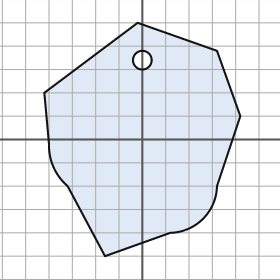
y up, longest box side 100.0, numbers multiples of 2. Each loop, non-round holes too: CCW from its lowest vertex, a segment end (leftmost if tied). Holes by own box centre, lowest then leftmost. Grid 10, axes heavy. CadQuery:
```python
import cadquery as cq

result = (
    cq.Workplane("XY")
    .moveTo(-16.0, -50.0)
    .lineTo(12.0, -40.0)
    .threePointArc((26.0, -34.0), (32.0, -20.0))
    .lineTo(42.0, 10.0)
    .lineTo(32.0, 38.0)
    .lineTo(-2.0, 50.0)
    .lineTo(-42.0, 20.0)
    .lineTo(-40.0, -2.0)
    .threePointArc((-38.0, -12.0), (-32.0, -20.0))
    .close()
    .moveTo(0.0, 34.0)
    .circle(4.0)
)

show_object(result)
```